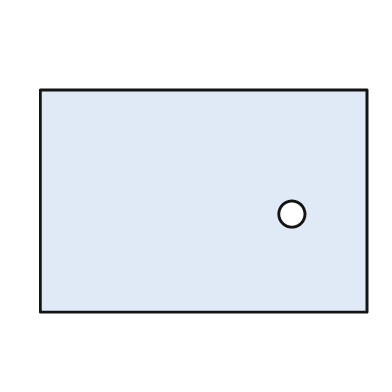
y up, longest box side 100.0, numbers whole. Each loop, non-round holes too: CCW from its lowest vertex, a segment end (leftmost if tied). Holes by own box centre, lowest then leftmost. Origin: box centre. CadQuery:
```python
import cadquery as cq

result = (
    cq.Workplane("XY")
    .moveTo(-50.0, -34.0)
    .lineTo(50.0, -34.0)
    .lineTo(50.0, 34.0)
    .lineTo(-50.0, 34.0)
    .close()
    .moveTo(27.0, -4.0)
    .circle(4.0)
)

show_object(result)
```